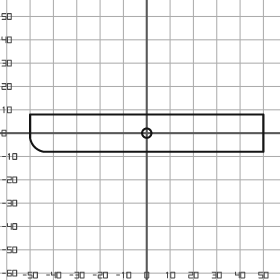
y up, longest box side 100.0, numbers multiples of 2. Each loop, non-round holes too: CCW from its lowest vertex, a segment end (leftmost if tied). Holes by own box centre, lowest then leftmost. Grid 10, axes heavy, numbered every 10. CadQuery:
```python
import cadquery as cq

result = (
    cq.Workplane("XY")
    .moveTo(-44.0, -8.0)
    .lineTo(50.0, -8.0)
    .lineTo(50.0, 8.0)
    .lineTo(-50.0, 8.0)
    .lineTo(-50.0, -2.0)
    .threePointArc((-48.0, -6.0), (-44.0, -8.0))
    .close()
    .moveTo(0.0, 0.0)
    .circle(2.0)
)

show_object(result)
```